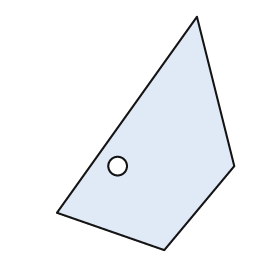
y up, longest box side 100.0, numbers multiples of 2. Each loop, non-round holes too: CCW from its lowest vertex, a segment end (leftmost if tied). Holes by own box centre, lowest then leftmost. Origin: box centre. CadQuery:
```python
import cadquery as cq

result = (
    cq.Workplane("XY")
    .moveTo(8.0, -50.0)
    .lineTo(38.0, -14.0)
    .lineTo(22.0, 50.0)
    .lineTo(-38.0, -34.0)
    .close()
    .moveTo(-12.0, -14.0)
    .circle(4.0)
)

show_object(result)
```